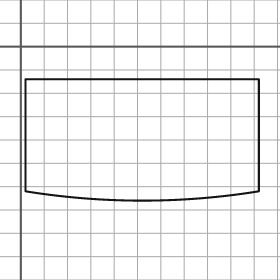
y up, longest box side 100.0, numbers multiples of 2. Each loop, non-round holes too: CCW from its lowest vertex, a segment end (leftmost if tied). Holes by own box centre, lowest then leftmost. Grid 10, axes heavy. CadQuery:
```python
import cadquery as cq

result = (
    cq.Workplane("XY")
    .moveTo(2.0, -62.0)
    .threePointArc((52.0, -66.0), (102.0, -62.0))
    .lineTo(102.0, -14.0)
    .lineTo(2.0, -14.0)
    .close()
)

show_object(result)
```